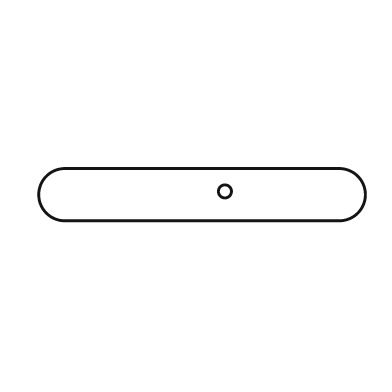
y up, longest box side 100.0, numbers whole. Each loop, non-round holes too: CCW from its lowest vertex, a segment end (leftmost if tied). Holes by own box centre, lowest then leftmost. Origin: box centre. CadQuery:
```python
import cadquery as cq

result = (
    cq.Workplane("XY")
    .moveTo(-42.0, -8.0)
    .lineTo(42.0, -8.0)
    .threePointArc((50.0, 0.0), (42.0, 8.0))
    .lineTo(-42.0, 8.0)
    .threePointArc((-50.0, 0.0), (-42.0, -8.0))
    .close()
    .moveTo(7.0, 1.0)
    .circle(2.0)
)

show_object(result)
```